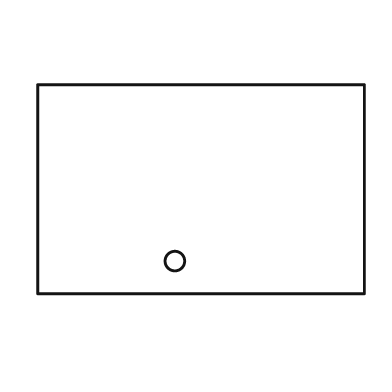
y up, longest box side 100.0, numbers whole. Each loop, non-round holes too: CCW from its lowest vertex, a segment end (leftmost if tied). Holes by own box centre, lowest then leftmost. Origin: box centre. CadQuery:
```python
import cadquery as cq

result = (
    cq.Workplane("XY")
    .moveTo(-50.0, -32.0)
    .lineTo(50.0, -32.0)
    .lineTo(50.0, 32.0)
    .lineTo(-50.0, 32.0)
    .close()
    .moveTo(-8.0, -22.0)
    .circle(3.0)
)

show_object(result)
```